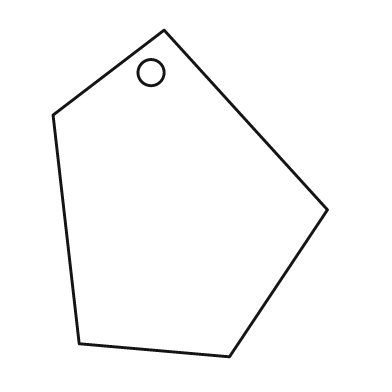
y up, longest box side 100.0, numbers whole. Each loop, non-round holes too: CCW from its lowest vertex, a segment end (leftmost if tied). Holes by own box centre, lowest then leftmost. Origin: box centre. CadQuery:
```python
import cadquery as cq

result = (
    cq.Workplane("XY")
    .moveTo(12.0, -50.0)
    .lineTo(42.0, -5.0)
    .lineTo(-8.0, 50.0)
    .lineTo(-42.0, 24.0)
    .lineTo(-34.0, -46.0)
    .close()
    .moveTo(-12.0, 37.0)
    .circle(4.0)
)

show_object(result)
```